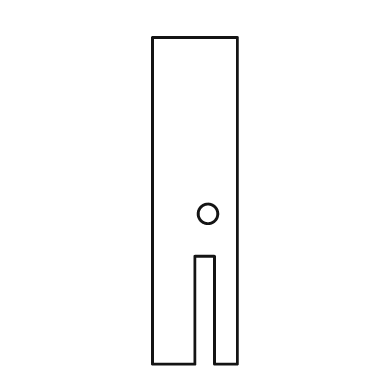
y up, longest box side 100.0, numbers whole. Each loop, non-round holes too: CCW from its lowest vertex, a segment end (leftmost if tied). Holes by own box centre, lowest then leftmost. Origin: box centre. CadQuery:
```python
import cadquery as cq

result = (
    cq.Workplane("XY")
    .moveTo(-13.0, -50.0)
    .lineTo(0.0, -50.0)
    .lineTo(0.0, -17.0)
    .lineTo(6.0, -17.0)
    .lineTo(6.0, -50.0)
    .lineTo(13.0, -50.0)
    .lineTo(13.0, 50.0)
    .lineTo(-13.0, 50.0)
    .close()
    .moveTo(4.0, -4.0)
    .circle(3.0)
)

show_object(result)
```